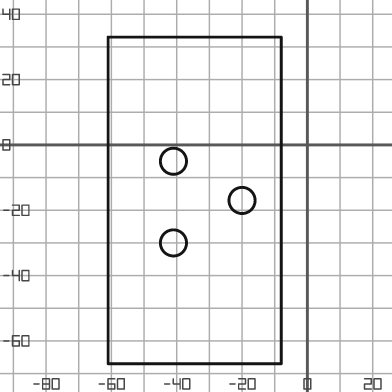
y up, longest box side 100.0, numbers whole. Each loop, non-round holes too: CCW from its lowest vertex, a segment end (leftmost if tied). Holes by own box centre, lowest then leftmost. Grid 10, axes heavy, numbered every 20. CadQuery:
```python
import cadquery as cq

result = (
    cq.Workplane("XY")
    .moveTo(-61.0, -67.0)
    .lineTo(-8.0, -67.0)
    .lineTo(-8.0, 33.0)
    .lineTo(-61.0, 33.0)
    .close()
    .moveTo(-41.0, -30.0)
    .circle(4.0)
    .moveTo(-20.0, -17.0)
    .circle(4.0)
    .moveTo(-41.0, -5.0)
    .circle(4.0)
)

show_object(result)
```